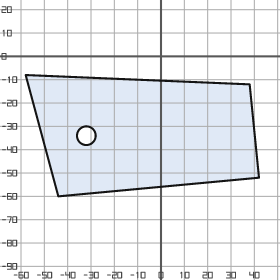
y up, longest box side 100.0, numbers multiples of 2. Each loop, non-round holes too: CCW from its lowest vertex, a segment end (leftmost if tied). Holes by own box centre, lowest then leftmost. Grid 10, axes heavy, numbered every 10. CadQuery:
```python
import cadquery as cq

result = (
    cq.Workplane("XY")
    .moveTo(-44.0, -60.0)
    .lineTo(42.0, -52.0)
    .lineTo(38.0, -12.0)
    .lineTo(-58.0, -8.0)
    .close()
    .moveTo(-32.0, -34.0)
    .circle(4.0)
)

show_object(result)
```